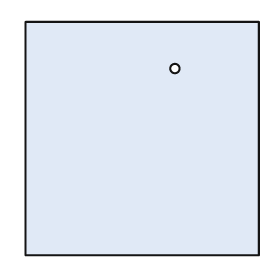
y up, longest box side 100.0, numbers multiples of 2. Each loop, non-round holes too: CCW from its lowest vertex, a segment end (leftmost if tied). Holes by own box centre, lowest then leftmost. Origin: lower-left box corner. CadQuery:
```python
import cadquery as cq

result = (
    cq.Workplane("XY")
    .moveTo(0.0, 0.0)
    .lineTo(100.0, 0.0)
    .lineTo(100.0, 100.0)
    .lineTo(0.0, 100.0)
    .close()
    .moveTo(64.0, 80.0)
    .circle(2.0)
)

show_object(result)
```